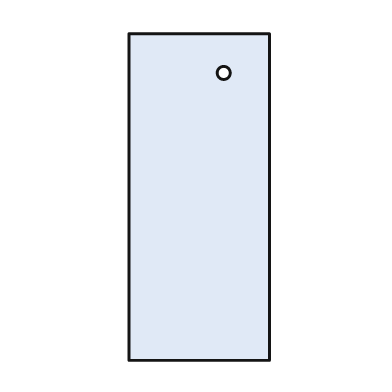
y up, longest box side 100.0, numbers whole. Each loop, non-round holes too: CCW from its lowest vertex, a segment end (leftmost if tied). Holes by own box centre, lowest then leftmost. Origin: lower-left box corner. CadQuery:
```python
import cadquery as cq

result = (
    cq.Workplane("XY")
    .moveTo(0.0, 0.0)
    .lineTo(43.0, 0.0)
    .lineTo(43.0, 100.0)
    .lineTo(0.0, 100.0)
    .close()
    .moveTo(29.0, 88.0)
    .circle(2.0)
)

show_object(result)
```